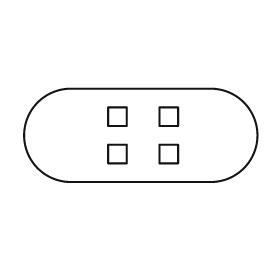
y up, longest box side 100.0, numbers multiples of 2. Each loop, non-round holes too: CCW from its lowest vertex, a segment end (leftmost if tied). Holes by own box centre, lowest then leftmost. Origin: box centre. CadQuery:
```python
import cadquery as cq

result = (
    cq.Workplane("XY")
    .moveTo(-30.0, -20.0)
    .lineTo(30.0, -20.0)
    .threePointArc((50.0, 0.0), (30.0, 20.0))
    .lineTo(-30.0, 20.0)
    .threePointArc((-50.0, 0.0), (-30.0, -20.0))
    .close()
    .moveTo(-14.0, -12.0)
    .lineTo(-6.0, -12.0)
    .lineTo(-6.0, -4.0)
    .lineTo(-14.0, -4.0)
    .close()
    .moveTo(8.0, -12.0)
    .lineTo(16.0, -12.0)
    .lineTo(16.0, -4.0)
    .lineTo(8.0, -4.0)
    .close()
    .moveTo(-14.0, 4.0)
    .lineTo(-6.0, 4.0)
    .lineTo(-6.0, 12.0)
    .lineTo(-14.0, 12.0)
    .close()
    .moveTo(8.0, 4.0)
    .lineTo(16.0, 4.0)
    .lineTo(16.0, 12.0)
    .lineTo(8.0, 12.0)
    .close()
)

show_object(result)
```